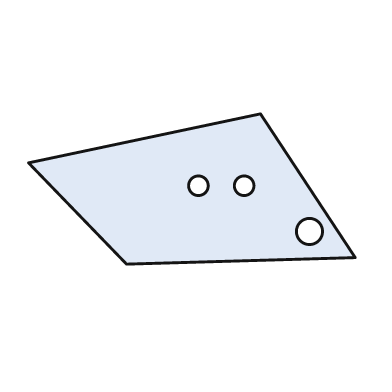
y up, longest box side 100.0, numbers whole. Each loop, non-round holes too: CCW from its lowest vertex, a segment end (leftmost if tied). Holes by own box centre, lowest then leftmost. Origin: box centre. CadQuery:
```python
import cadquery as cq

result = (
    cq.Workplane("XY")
    .moveTo(-20.0, -23.0)
    .lineTo(50.0, -21.0)
    .lineTo(21.0, 23.0)
    .lineTo(-50.0, 8.0)
    .close()
    .moveTo(36.0, -13.0)
    .circle(4.0)
    .moveTo(2.0, 1.0)
    .circle(3.0)
    .moveTo(16.0, 1.0)
    .circle(3.0)
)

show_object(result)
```